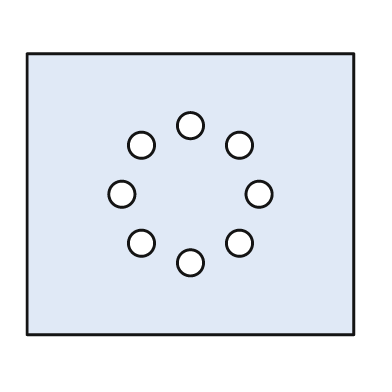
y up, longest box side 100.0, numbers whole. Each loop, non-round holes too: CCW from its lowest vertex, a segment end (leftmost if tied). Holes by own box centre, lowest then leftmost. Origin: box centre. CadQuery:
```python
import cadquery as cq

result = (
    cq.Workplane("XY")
    .moveTo(-50.0, -43.0)
    .lineTo(50.0, -43.0)
    .lineTo(50.0, 43.0)
    .lineTo(-50.0, 43.0)
    .close()
    .moveTo(0.0, -21.0)
    .circle(4.0)
    .moveTo(-15.0, -15.0)
    .circle(4.0)
    .moveTo(15.0, -15.0)
    .circle(4.0)
    .moveTo(-21.0, 0.0)
    .circle(4.0)
    .moveTo(21.0, 0.0)
    .circle(4.0)
    .moveTo(-15.0, 15.0)
    .circle(4.0)
    .moveTo(15.0, 15.0)
    .circle(4.0)
    .moveTo(0.0, 21.0)
    .circle(4.0)
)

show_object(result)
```